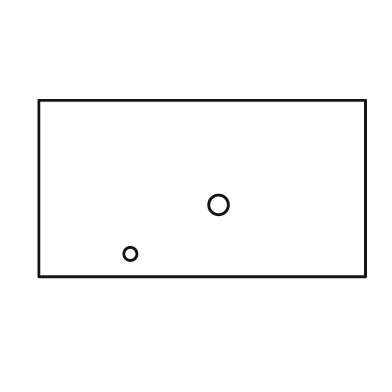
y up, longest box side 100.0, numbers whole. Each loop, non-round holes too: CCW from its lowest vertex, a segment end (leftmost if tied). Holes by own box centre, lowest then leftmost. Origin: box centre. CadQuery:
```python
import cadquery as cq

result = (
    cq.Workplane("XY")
    .moveTo(-50.0, -27.0)
    .lineTo(50.0, -27.0)
    .lineTo(50.0, 27.0)
    .lineTo(-50.0, 27.0)
    .close()
    .moveTo(-22.0, -20.0)
    .circle(2.0)
    .moveTo(5.0, -5.0)
    .circle(3.0)
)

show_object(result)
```